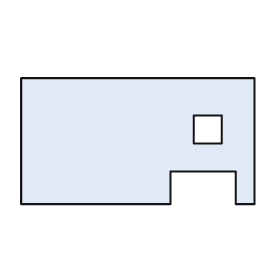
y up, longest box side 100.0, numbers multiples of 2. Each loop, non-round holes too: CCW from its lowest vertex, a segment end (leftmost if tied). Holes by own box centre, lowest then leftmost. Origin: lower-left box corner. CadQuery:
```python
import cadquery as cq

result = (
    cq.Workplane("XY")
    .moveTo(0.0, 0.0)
    .lineTo(64.0, 0.0)
    .lineTo(64.0, 14.0)
    .lineTo(92.0, 14.0)
    .lineTo(92.0, 0.0)
    .lineTo(100.0, 0.0)
    .lineTo(100.0, 54.0)
    .lineTo(0.0, 54.0)
    .close()
    .moveTo(74.0, 26.0)
    .lineTo(86.0, 26.0)
    .lineTo(86.0, 38.0)
    .lineTo(74.0, 38.0)
    .close()
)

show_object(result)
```